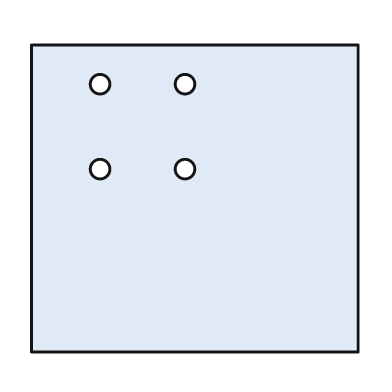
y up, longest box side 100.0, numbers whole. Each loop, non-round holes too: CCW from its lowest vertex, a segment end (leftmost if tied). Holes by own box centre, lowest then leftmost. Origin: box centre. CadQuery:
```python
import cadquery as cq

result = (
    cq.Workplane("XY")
    .moveTo(-50.0, -47.0)
    .lineTo(50.0, -47.0)
    .lineTo(50.0, 47.0)
    .lineTo(-50.0, 47.0)
    .close()
    .moveTo(-29.0, 9.0)
    .circle(3.0)
    .moveTo(-3.0, 9.0)
    .circle(3.0)
    .moveTo(-29.0, 35.0)
    .circle(3.0)
    .moveTo(-3.0, 35.0)
    .circle(3.0)
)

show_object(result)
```